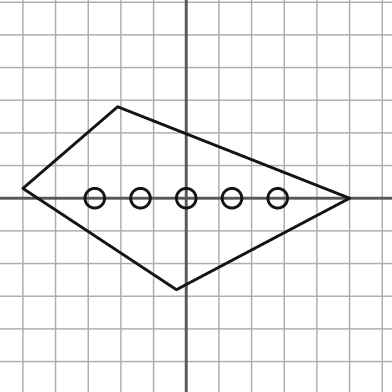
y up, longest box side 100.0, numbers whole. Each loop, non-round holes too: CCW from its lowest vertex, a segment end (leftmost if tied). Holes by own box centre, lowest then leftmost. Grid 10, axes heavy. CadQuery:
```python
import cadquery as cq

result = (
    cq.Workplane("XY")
    .moveTo(-3.0, -28.0)
    .lineTo(50.0, 0.0)
    .lineTo(-21.0, 28.0)
    .lineTo(-50.0, 3.0)
    .close()
    .moveTo(-28.0, 0.0)
    .circle(3.0)
    .moveTo(-14.0, 0.0)
    .circle(3.0)
    .moveTo(0.0, 0.0)
    .circle(3.0)
    .moveTo(14.0, 0.0)
    .circle(3.0)
    .moveTo(28.0, 0.0)
    .circle(3.0)
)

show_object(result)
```